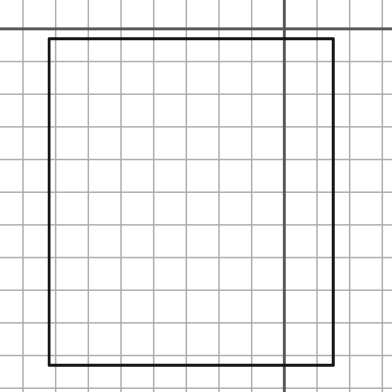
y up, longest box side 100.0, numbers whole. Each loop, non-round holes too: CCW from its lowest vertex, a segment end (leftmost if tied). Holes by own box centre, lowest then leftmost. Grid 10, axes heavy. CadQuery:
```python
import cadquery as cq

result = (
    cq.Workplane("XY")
    .moveTo(-72.0, -103.0)
    .lineTo(15.0, -103.0)
    .lineTo(15.0, -3.0)
    .lineTo(-72.0, -3.0)
    .close()
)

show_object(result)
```